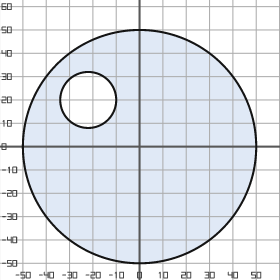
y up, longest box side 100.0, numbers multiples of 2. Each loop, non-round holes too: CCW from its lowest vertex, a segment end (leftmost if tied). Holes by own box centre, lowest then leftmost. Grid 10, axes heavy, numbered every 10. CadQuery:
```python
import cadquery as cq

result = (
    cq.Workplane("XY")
    .moveTo(0.0, 0.0)
    .circle(50.0)
    .moveTo(-22.0, 20.0)
    .circle(12.0)
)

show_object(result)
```